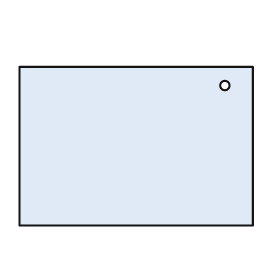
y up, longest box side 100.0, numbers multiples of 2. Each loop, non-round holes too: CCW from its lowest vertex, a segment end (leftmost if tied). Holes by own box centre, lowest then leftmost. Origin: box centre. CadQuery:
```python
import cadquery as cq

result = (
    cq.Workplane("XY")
    .moveTo(-50.0, -34.0)
    .lineTo(50.0, -34.0)
    .lineTo(50.0, 34.0)
    .lineTo(-50.0, 34.0)
    .close()
    .moveTo(38.0, 26.0)
    .circle(2.0)
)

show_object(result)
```